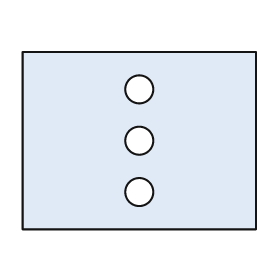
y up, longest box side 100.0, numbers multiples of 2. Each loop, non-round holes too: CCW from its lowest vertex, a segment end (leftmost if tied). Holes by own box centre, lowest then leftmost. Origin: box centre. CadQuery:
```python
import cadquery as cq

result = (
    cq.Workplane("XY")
    .moveTo(-50.0, -38.0)
    .lineTo(50.0, -38.0)
    .lineTo(50.0, 38.0)
    .lineTo(-50.0, 38.0)
    .close()
    .moveTo(0.0, -22.0)
    .circle(6.0)
    .moveTo(0.0, 0.0)
    .circle(6.0)
    .moveTo(0.0, 22.0)
    .circle(6.0)
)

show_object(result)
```